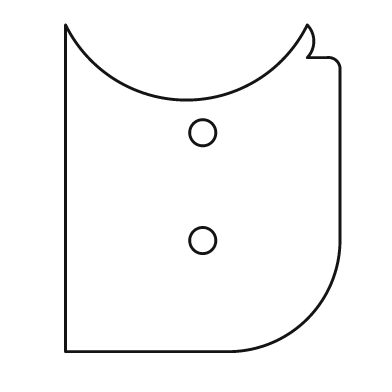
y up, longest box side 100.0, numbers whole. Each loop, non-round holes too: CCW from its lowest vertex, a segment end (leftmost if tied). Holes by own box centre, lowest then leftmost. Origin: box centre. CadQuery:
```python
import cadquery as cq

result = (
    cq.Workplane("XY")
    .moveTo(-42.0, -50.0)
    .lineTo(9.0, -50.0)
    .threePointArc((32.0, -40.0), (42.0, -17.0))
    .lineTo(42.0, 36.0)
    .threePointArc((41.0, 39.0), (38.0, 40.0))
    .lineTo(32.0, 40.0)
    .threePointArc((34.0, 45.0), (32.0, 50.0))
    .threePointArc((-5.0, 27.0), (-42.0, 50.0))
    .close()
    .moveTo(0.0, -16.0)
    .circle(4.0)
    .moveTo(0.0, 17.0)
    .circle(4.0)
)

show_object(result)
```